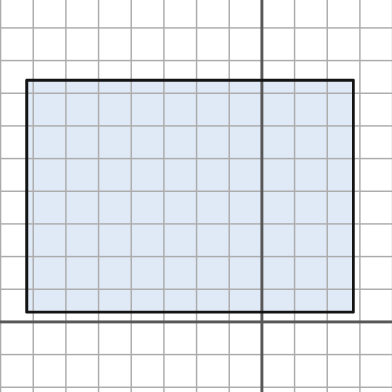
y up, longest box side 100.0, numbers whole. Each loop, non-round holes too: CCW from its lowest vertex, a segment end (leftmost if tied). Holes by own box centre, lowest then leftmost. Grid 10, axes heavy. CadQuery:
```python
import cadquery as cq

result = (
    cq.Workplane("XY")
    .moveTo(-72.0, 3.0)
    .lineTo(28.0, 3.0)
    .lineTo(28.0, 74.0)
    .lineTo(-72.0, 74.0)
    .close()
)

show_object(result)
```